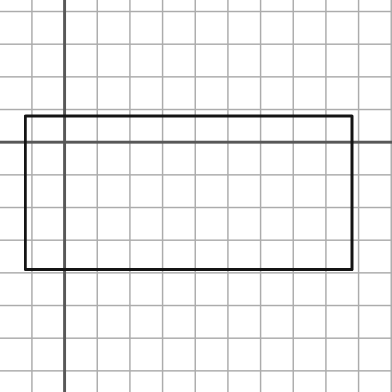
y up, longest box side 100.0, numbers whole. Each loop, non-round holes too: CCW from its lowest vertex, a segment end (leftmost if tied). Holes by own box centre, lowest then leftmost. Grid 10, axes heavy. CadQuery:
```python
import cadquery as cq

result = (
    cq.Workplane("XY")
    .moveTo(-12.0, -39.0)
    .lineTo(88.0, -39.0)
    .lineTo(88.0, 8.0)
    .lineTo(-12.0, 8.0)
    .close()
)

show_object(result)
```